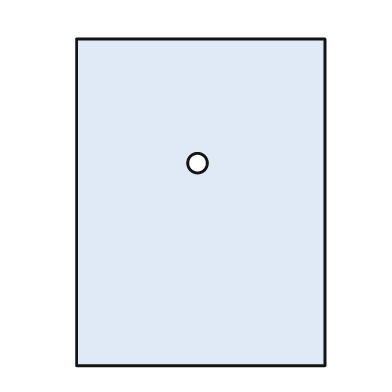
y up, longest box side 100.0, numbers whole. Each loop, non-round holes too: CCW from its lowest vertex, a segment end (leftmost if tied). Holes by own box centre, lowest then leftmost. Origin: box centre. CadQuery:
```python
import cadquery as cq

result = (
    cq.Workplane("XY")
    .moveTo(-38.0, -50.0)
    .lineTo(38.0, -50.0)
    .lineTo(38.0, 50.0)
    .lineTo(-38.0, 50.0)
    .close()
    .moveTo(-1.0, 12.0)
    .circle(3.0)
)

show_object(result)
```